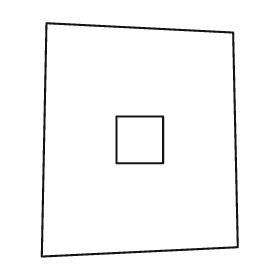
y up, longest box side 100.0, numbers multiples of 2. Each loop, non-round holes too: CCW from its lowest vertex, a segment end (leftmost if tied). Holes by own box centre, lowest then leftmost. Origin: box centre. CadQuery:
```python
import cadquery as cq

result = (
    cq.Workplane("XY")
    .moveTo(-42.0, -50.0)
    .lineTo(42.0, -46.0)
    .lineTo(40.0, 46.0)
    .lineTo(-40.0, 50.0)
    .close()
    .moveTo(-10.0, -10.0)
    .lineTo(10.0, -10.0)
    .lineTo(10.0, 10.0)
    .lineTo(-10.0, 10.0)
    .close()
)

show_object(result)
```